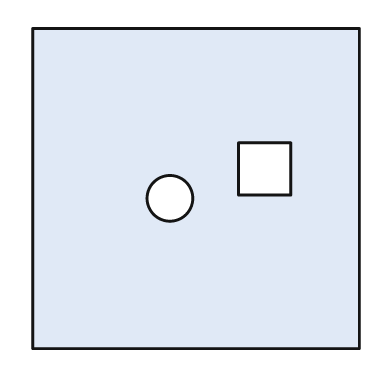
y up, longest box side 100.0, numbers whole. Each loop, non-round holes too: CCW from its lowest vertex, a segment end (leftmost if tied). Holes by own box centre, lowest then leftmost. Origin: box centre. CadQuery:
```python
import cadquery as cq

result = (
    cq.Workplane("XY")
    .moveTo(-50.0, -49.0)
    .lineTo(50.0, -49.0)
    .lineTo(50.0, 49.0)
    .lineTo(-50.0, 49.0)
    .close()
    .moveTo(-8.0, -3.0)
    .circle(7.0)
    .moveTo(13.0, -2.0)
    .lineTo(29.0, -2.0)
    .lineTo(29.0, 14.0)
    .lineTo(13.0, 14.0)
    .close()
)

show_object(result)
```